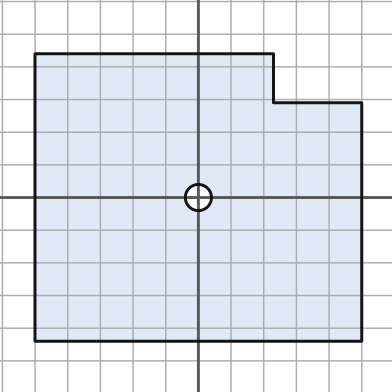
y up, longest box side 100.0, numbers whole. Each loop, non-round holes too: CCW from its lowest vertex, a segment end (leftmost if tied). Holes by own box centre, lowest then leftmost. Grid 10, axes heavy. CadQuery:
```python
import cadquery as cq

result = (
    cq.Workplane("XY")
    .moveTo(-50.0, -44.0)
    .lineTo(50.0, -44.0)
    .lineTo(50.0, 29.0)
    .lineTo(23.0, 29.0)
    .lineTo(23.0, 44.0)
    .lineTo(-50.0, 44.0)
    .close()
    .moveTo(0.0, 0.0)
    .circle(4.0)
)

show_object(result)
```